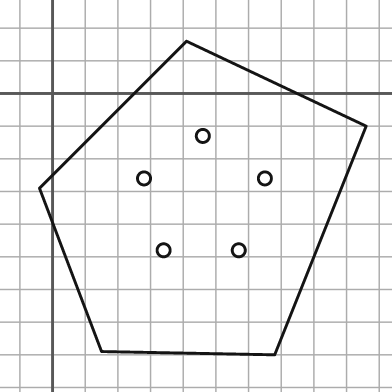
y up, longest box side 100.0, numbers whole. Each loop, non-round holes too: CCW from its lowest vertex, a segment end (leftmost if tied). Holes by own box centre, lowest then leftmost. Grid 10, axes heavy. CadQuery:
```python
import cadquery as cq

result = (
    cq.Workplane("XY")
    .moveTo(68.0, -80.0)
    .lineTo(96.0, -10.0)
    .lineTo(41.0, 16.0)
    .lineTo(-4.0, -29.0)
    .lineTo(15.0, -79.0)
    .close()
    .moveTo(34.0, -48.0)
    .circle(2.0)
    .moveTo(57.0, -48.0)
    .circle(2.0)
    .moveTo(28.0, -26.0)
    .circle(2.0)
    .moveTo(65.0, -26.0)
    .circle(2.0)
    .moveTo(46.0, -13.0)
    .circle(2.0)
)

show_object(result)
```